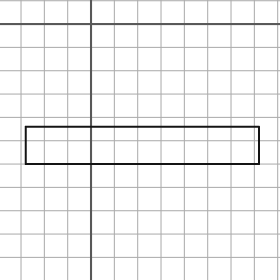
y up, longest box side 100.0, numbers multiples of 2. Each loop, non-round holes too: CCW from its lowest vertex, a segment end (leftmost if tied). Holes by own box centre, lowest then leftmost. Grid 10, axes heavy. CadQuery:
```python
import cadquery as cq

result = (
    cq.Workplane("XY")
    .moveTo(-28.0, -60.0)
    .lineTo(72.0, -60.0)
    .lineTo(72.0, -44.0)
    .lineTo(-28.0, -44.0)
    .close()
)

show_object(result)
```